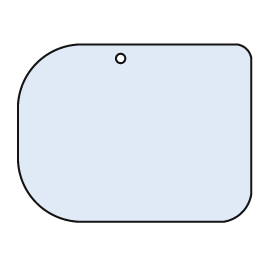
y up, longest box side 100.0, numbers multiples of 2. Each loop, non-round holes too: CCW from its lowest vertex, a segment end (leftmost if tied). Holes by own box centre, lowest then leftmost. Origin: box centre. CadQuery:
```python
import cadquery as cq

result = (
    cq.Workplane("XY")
    .moveTo(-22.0, -38.0)
    .lineTo(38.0, -38.0)
    .threePointArc((46.0, -34.0), (50.0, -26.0))
    .lineTo(50.0, 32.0)
    .threePointArc((48.0, 36.0), (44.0, 38.0))
    .lineTo(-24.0, 38.0)
    .threePointArc((-42.0, 30.0), (-50.0, 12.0))
    .lineTo(-50.0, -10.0)
    .threePointArc((-42.0, -30.0), (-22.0, -38.0))
    .close()
    .moveTo(-6.0, 32.0)
    .circle(2.0)
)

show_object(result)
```